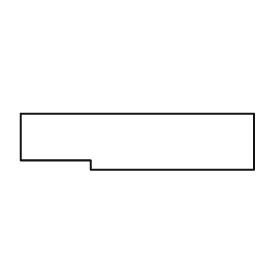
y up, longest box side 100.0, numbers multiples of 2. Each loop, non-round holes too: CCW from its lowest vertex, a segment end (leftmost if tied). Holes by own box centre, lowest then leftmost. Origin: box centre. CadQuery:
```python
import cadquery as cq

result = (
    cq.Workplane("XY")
    .moveTo(-20.0, -12.0)
    .lineTo(50.0, -12.0)
    .lineTo(50.0, 12.0)
    .lineTo(-50.0, 12.0)
    .lineTo(-50.0, -8.0)
    .lineTo(-20.0, -8.0)
    .close()
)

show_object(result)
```